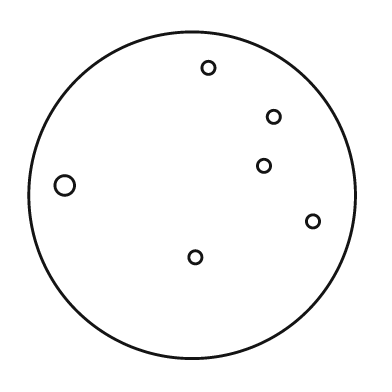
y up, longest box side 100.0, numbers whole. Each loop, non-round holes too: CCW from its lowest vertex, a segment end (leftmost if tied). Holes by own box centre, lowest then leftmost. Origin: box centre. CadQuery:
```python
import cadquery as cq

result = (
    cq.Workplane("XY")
    .moveTo(0.0, 0.0)
    .circle(50.0)
    .moveTo(1.0, -19.0)
    .circle(2.0)
    .moveTo(37.0, -8.0)
    .circle(2.0)
    .moveTo(-39.0, 3.0)
    .circle(3.0)
    .moveTo(22.0, 9.0)
    .circle(2.0)
    .moveTo(25.0, 24.0)
    .circle(2.0)
    .moveTo(5.0, 39.0)
    .circle(2.0)
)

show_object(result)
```